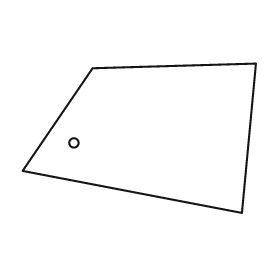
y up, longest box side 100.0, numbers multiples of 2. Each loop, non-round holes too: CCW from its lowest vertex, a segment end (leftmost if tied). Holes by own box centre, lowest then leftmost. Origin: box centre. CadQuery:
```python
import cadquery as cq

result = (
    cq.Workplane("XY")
    .moveTo(44.0, -32.0)
    .lineTo(50.0, 32.0)
    .lineTo(-20.0, 30.0)
    .lineTo(-50.0, -14.0)
    .close()
    .moveTo(-28.0, -2.0)
    .circle(2.0)
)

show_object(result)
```